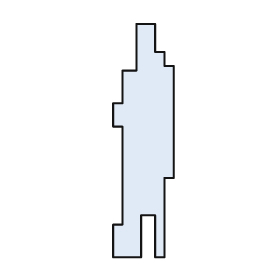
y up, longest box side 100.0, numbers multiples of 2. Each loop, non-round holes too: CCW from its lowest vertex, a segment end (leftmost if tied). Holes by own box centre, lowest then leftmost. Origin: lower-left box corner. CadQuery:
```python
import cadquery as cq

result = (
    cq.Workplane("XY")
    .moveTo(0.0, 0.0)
    .lineTo(12.0, 0.0)
    .lineTo(12.0, 18.0)
    .lineTo(18.0, 18.0)
    .lineTo(18.0, 0.0)
    .lineTo(22.0, 0.0)
    .lineTo(22.0, 34.0)
    .lineTo(26.0, 34.0)
    .lineTo(26.0, 82.0)
    .lineTo(22.0, 82.0)
    .lineTo(22.0, 88.0)
    .lineTo(18.0, 88.0)
    .lineTo(18.0, 100.0)
    .lineTo(10.0, 100.0)
    .lineTo(10.0, 80.0)
    .lineTo(4.0, 80.0)
    .lineTo(4.0, 66.0)
    .lineTo(0.0, 66.0)
    .lineTo(0.0, 56.0)
    .lineTo(4.0, 56.0)
    .lineTo(4.0, 14.0)
    .lineTo(0.0, 14.0)
    .close()
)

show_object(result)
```